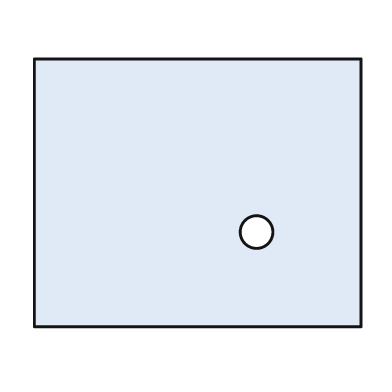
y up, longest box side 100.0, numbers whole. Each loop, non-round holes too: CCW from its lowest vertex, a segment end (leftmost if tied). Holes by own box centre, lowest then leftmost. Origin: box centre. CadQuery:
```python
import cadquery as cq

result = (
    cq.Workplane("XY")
    .moveTo(-50.0, -41.0)
    .lineTo(50.0, -41.0)
    .lineTo(50.0, 41.0)
    .lineTo(-50.0, 41.0)
    .close()
    .moveTo(18.0, -12.0)
    .circle(5.0)
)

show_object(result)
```